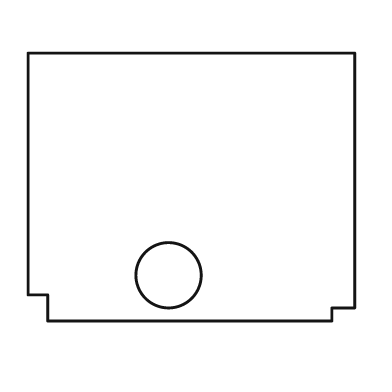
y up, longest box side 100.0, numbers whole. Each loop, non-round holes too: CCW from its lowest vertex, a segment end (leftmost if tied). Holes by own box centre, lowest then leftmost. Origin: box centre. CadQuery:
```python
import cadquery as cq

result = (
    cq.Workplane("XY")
    .moveTo(-44.0, -41.0)
    .lineTo(43.0, -41.0)
    .lineTo(43.0, -37.0)
    .lineTo(50.0, -37.0)
    .lineTo(50.0, 41.0)
    .lineTo(-50.0, 41.0)
    .lineTo(-50.0, -33.0)
    .lineTo(-44.0, -33.0)
    .close()
    .moveTo(-7.0, -27.0)
    .circle(10.0)
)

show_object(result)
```